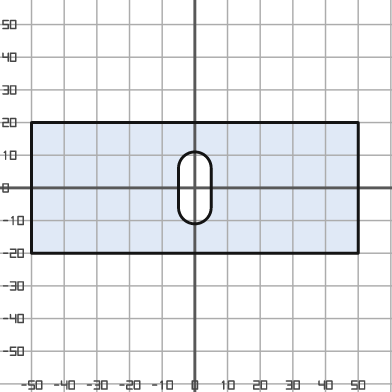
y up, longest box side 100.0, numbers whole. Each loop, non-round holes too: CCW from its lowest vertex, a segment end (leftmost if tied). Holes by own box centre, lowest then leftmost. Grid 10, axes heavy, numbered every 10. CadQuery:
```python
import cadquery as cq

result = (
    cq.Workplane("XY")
    .moveTo(-50.0, -20.0)
    .lineTo(50.0, -20.0)
    .lineTo(50.0, 20.0)
    .lineTo(-50.0, 20.0)
    .close()
    .moveTo(-5.0, -6.0)
    .threePointArc((0.0, -11.0), (5.0, -6.0))
    .lineTo(5.0, 6.0)
    .threePointArc((0.0, 11.0), (-5.0, 6.0))
    .close()
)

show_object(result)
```